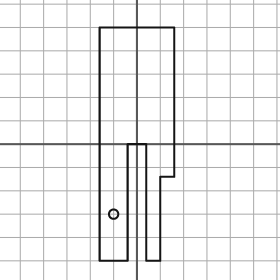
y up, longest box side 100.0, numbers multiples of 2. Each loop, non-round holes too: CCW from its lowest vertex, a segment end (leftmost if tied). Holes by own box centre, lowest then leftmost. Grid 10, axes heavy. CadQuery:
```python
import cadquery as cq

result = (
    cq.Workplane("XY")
    .moveTo(-16.0, -50.0)
    .lineTo(-4.0, -50.0)
    .lineTo(-4.0, 0.0)
    .lineTo(4.0, 0.0)
    .lineTo(4.0, -50.0)
    .lineTo(10.0, -50.0)
    .lineTo(10.0, -14.0)
    .lineTo(16.0, -14.0)
    .lineTo(16.0, 50.0)
    .lineTo(-16.0, 50.0)
    .close()
    .moveTo(-10.0, -30.0)
    .circle(2.0)
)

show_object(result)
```